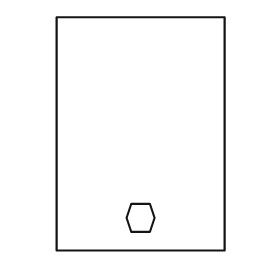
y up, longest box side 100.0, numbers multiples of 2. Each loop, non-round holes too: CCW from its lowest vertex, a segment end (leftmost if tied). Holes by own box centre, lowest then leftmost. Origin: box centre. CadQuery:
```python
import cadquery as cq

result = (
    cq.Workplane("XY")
    .moveTo(-36.0, -50.0)
    .lineTo(36.0, -50.0)
    .lineTo(36.0, 50.0)
    .lineTo(-36.0, 50.0)
    .close()
    .moveTo(-4.0, -42.0)
    .lineTo(4.0, -42.0)
    .lineTo(6.0, -36.0)
    .lineTo(4.0, -30.0)
    .lineTo(-4.0, -30.0)
    .lineTo(-6.0, -36.0)
    .close()
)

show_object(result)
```